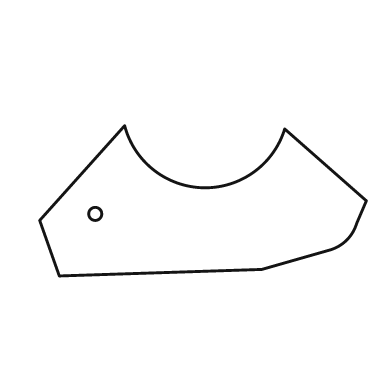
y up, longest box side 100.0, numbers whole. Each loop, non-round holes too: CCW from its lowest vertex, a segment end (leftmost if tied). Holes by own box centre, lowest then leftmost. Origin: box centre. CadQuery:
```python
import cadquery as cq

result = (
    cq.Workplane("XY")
    .moveTo(-44.0, -23.0)
    .lineTo(18.0, -21.0)
    .lineTo(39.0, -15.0)
    .threePointArc((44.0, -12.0), (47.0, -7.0))
    .lineTo(50.0, 0.0)
    .lineTo(25.0, 22.0)
    .threePointArc((0.0, 4.0), (-24.0, 23.0))
    .lineTo(-50.0, -6.0)
    .close()
    .moveTo(-33.0, -4.0)
    .circle(2.0)
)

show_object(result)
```